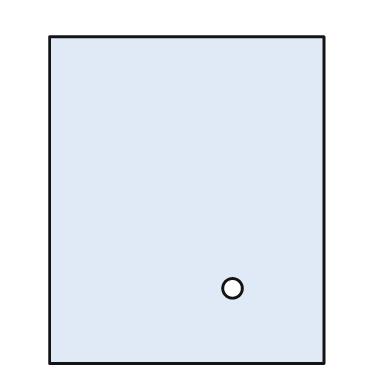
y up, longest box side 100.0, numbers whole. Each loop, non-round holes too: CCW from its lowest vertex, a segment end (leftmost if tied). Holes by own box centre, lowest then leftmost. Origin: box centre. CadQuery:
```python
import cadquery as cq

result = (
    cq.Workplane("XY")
    .moveTo(-42.0, -50.0)
    .lineTo(42.0, -50.0)
    .lineTo(42.0, 50.0)
    .lineTo(-42.0, 50.0)
    .close()
    .moveTo(14.0, -27.0)
    .circle(3.0)
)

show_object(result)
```